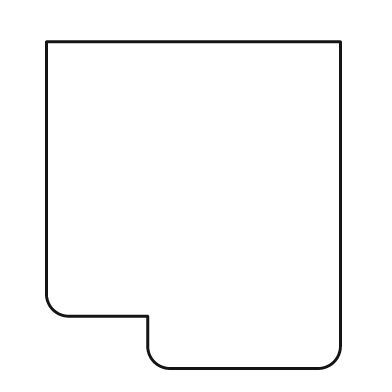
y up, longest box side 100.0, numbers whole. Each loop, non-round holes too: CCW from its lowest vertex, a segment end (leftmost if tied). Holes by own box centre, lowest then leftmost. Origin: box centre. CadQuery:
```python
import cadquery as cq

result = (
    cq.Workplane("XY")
    .moveTo(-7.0, -50.0)
    .lineTo(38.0, -50.0)
    .threePointArc((43.0, -48.0), (45.0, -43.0))
    .lineTo(45.0, 50.0)
    .lineTo(-45.0, 50.0)
    .lineTo(-45.0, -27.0)
    .threePointArc((-43.0, -32.0), (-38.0, -34.0))
    .lineTo(-14.0, -34.0)
    .lineTo(-14.0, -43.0)
    .threePointArc((-12.0, -48.0), (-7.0, -50.0))
    .close()
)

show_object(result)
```